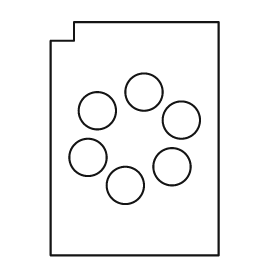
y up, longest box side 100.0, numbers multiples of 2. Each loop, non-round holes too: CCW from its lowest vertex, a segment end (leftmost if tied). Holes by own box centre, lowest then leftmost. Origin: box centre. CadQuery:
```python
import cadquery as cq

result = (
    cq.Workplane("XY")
    .moveTo(-36.0, -50.0)
    .lineTo(36.0, -50.0)
    .lineTo(36.0, 50.0)
    .lineTo(-26.0, 50.0)
    .lineTo(-26.0, 42.0)
    .lineTo(-36.0, 42.0)
    .close()
    .moveTo(-4.0, -20.0)
    .circle(8.0)
    .moveTo(16.0, -12.0)
    .circle(8.0)
    .moveTo(-20.0, -8.0)
    .circle(8.0)
    .moveTo(20.0, 8.0)
    .circle(8.0)
    .moveTo(-16.0, 12.0)
    .circle(8.0)
    .moveTo(4.0, 20.0)
    .circle(8.0)
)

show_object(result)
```